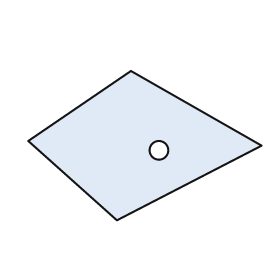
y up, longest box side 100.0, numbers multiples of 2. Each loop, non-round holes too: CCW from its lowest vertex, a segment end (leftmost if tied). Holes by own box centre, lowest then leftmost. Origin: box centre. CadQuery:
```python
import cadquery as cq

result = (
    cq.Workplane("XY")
    .moveTo(-12.0, -32.0)
    .lineTo(50.0, 0.0)
    .lineTo(-6.0, 32.0)
    .lineTo(-50.0, 2.0)
    .close()
    .moveTo(6.0, -2.0)
    .circle(4.0)
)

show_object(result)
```